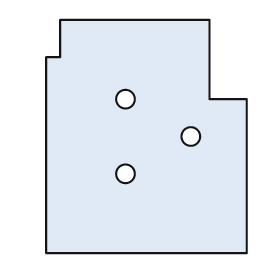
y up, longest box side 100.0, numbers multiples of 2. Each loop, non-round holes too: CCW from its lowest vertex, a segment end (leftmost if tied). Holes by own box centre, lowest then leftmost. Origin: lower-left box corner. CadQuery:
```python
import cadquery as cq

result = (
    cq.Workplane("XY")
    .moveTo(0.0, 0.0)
    .lineTo(86.0, 0.0)
    .lineTo(86.0, 66.0)
    .lineTo(70.0, 66.0)
    .lineTo(70.0, 100.0)
    .lineTo(6.0, 100.0)
    .lineTo(6.0, 84.0)
    .lineTo(0.0, 84.0)
    .close()
    .moveTo(34.0, 34.0)
    .circle(4.0)
    .moveTo(62.0, 50.0)
    .circle(4.0)
    .moveTo(34.0, 66.0)
    .circle(4.0)
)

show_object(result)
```